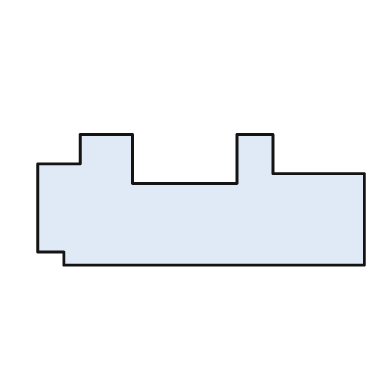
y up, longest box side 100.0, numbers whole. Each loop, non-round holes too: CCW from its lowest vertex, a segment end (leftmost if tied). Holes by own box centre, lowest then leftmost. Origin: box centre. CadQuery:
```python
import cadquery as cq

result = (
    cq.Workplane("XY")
    .moveTo(-42.0, -20.0)
    .lineTo(50.0, -20.0)
    .lineTo(50.0, 8.0)
    .lineTo(22.0, 8.0)
    .lineTo(22.0, 20.0)
    .lineTo(11.0, 20.0)
    .lineTo(11.0, 5.0)
    .lineTo(-21.0, 5.0)
    .lineTo(-21.0, 20.0)
    .lineTo(-37.0, 20.0)
    .lineTo(-37.0, 11.0)
    .lineTo(-50.0, 11.0)
    .lineTo(-50.0, -16.0)
    .lineTo(-42.0, -16.0)
    .close()
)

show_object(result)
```